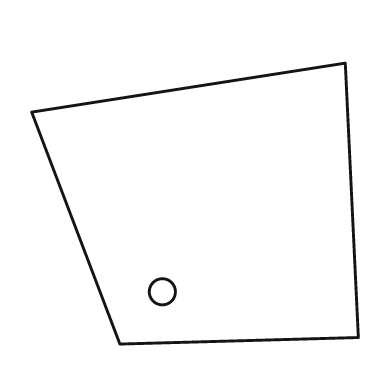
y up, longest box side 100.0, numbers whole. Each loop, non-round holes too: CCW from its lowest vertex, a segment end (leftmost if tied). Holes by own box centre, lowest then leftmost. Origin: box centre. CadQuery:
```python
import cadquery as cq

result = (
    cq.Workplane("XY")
    .moveTo(-23.0, -43.0)
    .lineTo(50.0, -41.0)
    .lineTo(46.0, 43.0)
    .lineTo(-50.0, 28.0)
    .close()
    .moveTo(-10.0, -27.0)
    .circle(4.0)
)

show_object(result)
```